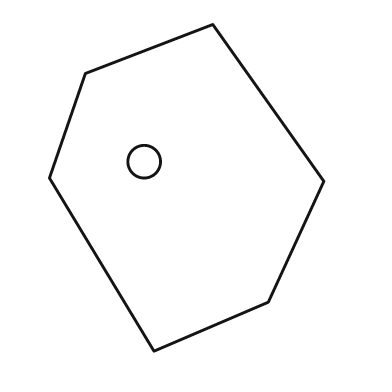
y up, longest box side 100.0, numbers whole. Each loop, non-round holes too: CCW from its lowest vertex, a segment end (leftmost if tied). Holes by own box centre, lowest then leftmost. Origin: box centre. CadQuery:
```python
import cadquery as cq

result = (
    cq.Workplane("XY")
    .moveTo(-10.0, -50.0)
    .lineTo(25.0, -35.0)
    .lineTo(42.0, 2.0)
    .lineTo(8.0, 50.0)
    .lineTo(-31.0, 35.0)
    .lineTo(-42.0, 3.0)
    .close()
    .moveTo(-13.0, 8.0)
    .circle(5.0)
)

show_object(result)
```